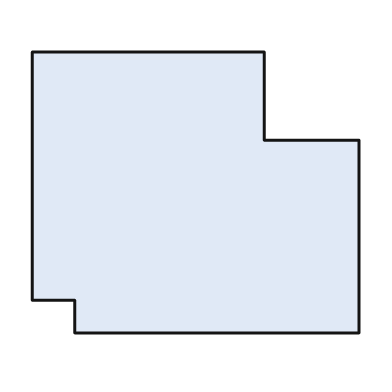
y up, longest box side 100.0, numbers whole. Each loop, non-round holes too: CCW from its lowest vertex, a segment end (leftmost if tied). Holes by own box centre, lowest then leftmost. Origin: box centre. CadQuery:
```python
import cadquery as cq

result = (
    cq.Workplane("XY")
    .moveTo(-37.0, -43.0)
    .lineTo(50.0, -43.0)
    .lineTo(50.0, 16.0)
    .lineTo(21.0, 16.0)
    .lineTo(21.0, 43.0)
    .lineTo(-50.0, 43.0)
    .lineTo(-50.0, -33.0)
    .lineTo(-37.0, -33.0)
    .close()
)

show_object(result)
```